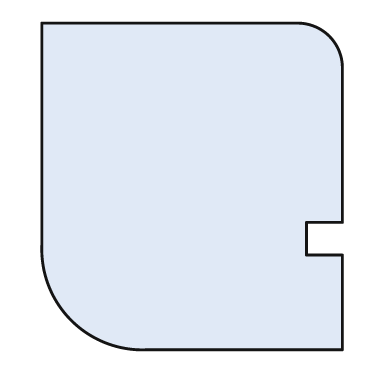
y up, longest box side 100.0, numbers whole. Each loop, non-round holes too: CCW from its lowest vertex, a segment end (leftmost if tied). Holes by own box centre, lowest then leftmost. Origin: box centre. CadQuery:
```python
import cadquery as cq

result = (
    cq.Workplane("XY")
    .moveTo(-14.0, -50.0)
    .lineTo(46.0, -50.0)
    .lineTo(46.0, -21.0)
    .lineTo(35.0, -21.0)
    .lineTo(35.0, -11.0)
    .lineTo(46.0, -11.0)
    .lineTo(46.0, 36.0)
    .threePointArc((42.0, 46.0), (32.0, 50.0))
    .lineTo(-46.0, 50.0)
    .lineTo(-46.0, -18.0)
    .threePointArc((-37.0, -41.0), (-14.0, -50.0))
    .close()
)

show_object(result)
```